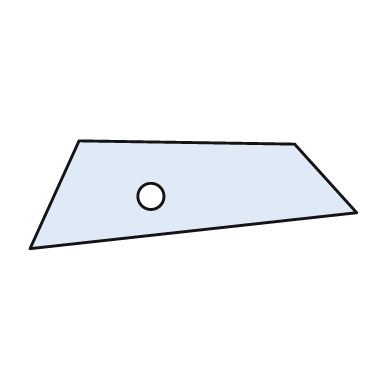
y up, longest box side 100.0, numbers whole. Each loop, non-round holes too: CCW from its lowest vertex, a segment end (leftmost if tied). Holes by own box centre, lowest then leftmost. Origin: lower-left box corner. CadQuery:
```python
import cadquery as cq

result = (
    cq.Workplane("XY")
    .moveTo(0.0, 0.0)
    .lineTo(100.0, 11.0)
    .lineTo(81.0, 32.0)
    .lineTo(15.0, 33.0)
    .close()
    .moveTo(37.0, 16.0)
    .circle(4.0)
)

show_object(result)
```